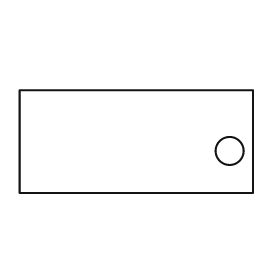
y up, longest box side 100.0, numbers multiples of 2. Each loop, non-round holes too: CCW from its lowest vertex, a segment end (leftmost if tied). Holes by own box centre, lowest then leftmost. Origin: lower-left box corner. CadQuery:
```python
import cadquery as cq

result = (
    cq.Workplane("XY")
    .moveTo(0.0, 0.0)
    .lineTo(100.0, 0.0)
    .lineTo(100.0, 44.0)
    .lineTo(0.0, 44.0)
    .close()
    .moveTo(90.0, 18.0)
    .circle(6.0)
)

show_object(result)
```